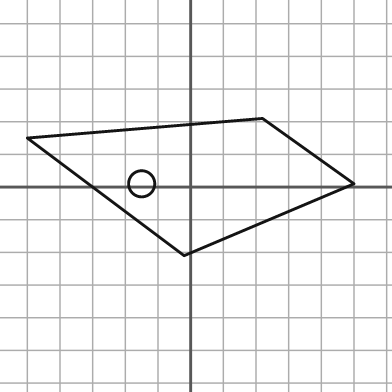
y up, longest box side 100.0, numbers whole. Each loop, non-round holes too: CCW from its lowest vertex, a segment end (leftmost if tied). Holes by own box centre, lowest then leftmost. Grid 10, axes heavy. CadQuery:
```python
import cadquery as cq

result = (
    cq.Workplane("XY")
    .moveTo(-2.0, -21.0)
    .lineTo(50.0, 1.0)
    .lineTo(22.0, 21.0)
    .lineTo(-50.0, 15.0)
    .close()
    .moveTo(-15.0, 1.0)
    .circle(4.0)
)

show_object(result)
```